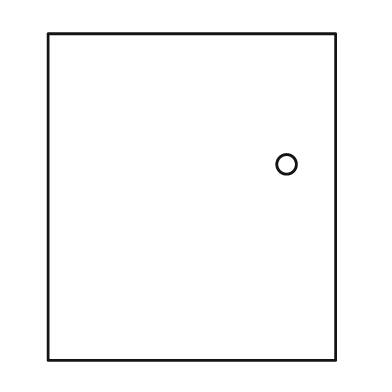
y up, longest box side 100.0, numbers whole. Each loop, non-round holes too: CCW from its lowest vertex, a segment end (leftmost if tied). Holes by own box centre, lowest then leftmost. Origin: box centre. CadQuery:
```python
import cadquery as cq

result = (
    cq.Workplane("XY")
    .moveTo(-44.0, -50.0)
    .lineTo(44.0, -50.0)
    .lineTo(44.0, 50.0)
    .lineTo(-44.0, 50.0)
    .close()
    .moveTo(29.0, 10.0)
    .circle(3.0)
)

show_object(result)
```